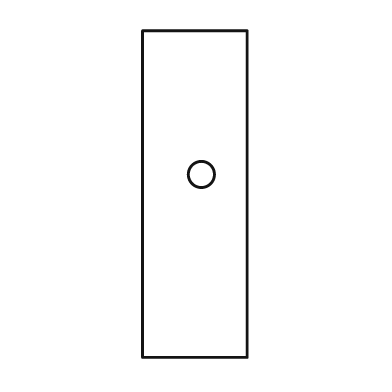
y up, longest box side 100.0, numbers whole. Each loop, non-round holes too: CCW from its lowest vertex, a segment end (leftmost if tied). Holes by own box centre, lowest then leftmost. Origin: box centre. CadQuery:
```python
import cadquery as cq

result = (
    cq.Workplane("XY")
    .moveTo(-16.0, -50.0)
    .lineTo(16.0, -50.0)
    .lineTo(16.0, 50.0)
    .lineTo(-16.0, 50.0)
    .close()
    .moveTo(2.0, 6.0)
    .circle(4.0)
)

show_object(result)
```